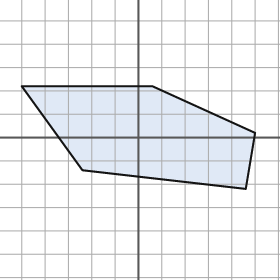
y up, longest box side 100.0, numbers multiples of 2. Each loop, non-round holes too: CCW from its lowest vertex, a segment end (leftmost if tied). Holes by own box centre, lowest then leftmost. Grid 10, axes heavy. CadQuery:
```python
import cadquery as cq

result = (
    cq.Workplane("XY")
    .moveTo(46.0, -22.0)
    .lineTo(50.0, 2.0)
    .lineTo(6.0, 22.0)
    .lineTo(-50.0, 22.0)
    .lineTo(-24.0, -14.0)
    .close()
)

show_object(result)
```